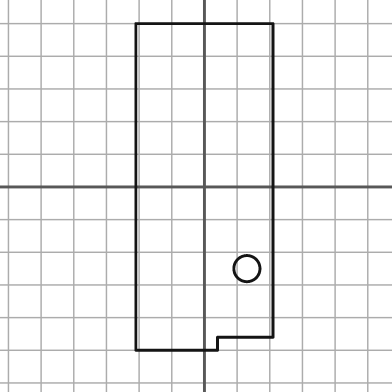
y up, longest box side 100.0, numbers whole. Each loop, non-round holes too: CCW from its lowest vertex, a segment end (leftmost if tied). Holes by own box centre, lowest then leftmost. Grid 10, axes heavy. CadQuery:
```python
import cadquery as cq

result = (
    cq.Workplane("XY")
    .moveTo(-21.0, -50.0)
    .lineTo(4.0, -50.0)
    .lineTo(4.0, -46.0)
    .lineTo(21.0, -46.0)
    .lineTo(21.0, 50.0)
    .lineTo(-21.0, 50.0)
    .close()
    .moveTo(13.0, -25.0)
    .circle(4.0)
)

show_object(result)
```